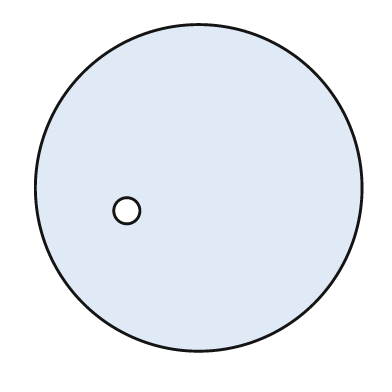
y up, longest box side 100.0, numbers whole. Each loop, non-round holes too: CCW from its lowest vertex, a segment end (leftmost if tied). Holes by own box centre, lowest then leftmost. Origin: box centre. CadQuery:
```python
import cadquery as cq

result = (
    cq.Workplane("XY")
    .moveTo(0.0, 0.0)
    .circle(50.0)
    .moveTo(-22.0, -7.0)
    .circle(4.0)
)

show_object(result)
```